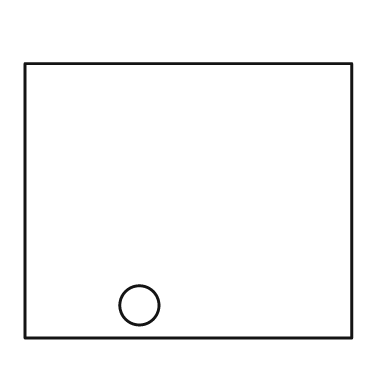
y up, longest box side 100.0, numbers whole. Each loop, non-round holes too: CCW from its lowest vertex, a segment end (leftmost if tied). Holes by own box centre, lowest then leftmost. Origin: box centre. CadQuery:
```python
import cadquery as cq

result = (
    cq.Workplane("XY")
    .moveTo(-50.0, -42.0)
    .lineTo(50.0, -42.0)
    .lineTo(50.0, 42.0)
    .lineTo(-50.0, 42.0)
    .close()
    .moveTo(-15.0, -32.0)
    .circle(6.0)
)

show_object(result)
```